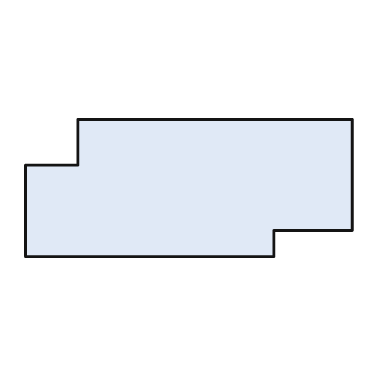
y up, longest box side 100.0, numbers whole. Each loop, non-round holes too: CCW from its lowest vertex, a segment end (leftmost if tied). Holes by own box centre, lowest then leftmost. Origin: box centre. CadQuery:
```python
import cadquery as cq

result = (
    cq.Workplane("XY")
    .moveTo(-50.0, -21.0)
    .lineTo(26.0, -21.0)
    .lineTo(26.0, -13.0)
    .lineTo(50.0, -13.0)
    .lineTo(50.0, 21.0)
    .lineTo(-34.0, 21.0)
    .lineTo(-34.0, 7.0)
    .lineTo(-50.0, 7.0)
    .close()
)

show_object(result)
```